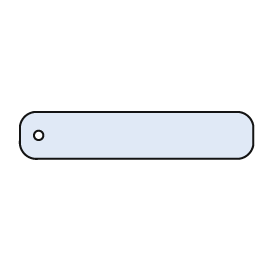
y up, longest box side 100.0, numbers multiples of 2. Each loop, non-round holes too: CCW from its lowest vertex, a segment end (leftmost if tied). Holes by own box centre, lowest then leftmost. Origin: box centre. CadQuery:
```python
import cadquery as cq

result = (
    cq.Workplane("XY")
    .moveTo(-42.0, -10.0)
    .lineTo(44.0, -10.0)
    .threePointArc((48.0, -8.0), (50.0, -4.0))
    .lineTo(50.0, 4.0)
    .threePointArc((48.0, 8.0), (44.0, 10.0))
    .lineTo(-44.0, 10.0)
    .threePointArc((-48.0, 8.0), (-50.0, 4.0))
    .lineTo(-50.0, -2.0)
    .threePointArc((-48.0, -8.0), (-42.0, -10.0))
    .close()
    .moveTo(-42.0, 0.0)
    .circle(2.0)
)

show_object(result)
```